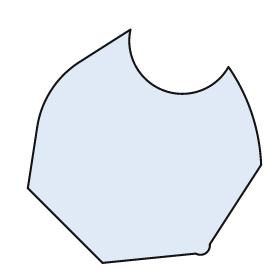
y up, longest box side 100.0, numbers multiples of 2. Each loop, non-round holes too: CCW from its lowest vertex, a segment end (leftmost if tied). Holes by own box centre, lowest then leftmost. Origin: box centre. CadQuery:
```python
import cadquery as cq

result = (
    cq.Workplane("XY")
    .moveTo(-18.0, -50.0)
    .lineTo(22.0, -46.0)
    .threePointArc((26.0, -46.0), (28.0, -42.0))
    .lineTo(50.0, -8.0)
    .threePointArc((46.0, 14.0), (36.0, 34.0))
    .threePointArc((8.0, 24.0), (-6.0, 50.0))
    .lineTo(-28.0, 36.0)
    .threePointArc((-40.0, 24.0), (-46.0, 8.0))
    .lineTo(-50.0, -18.0)
    .close()
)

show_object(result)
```